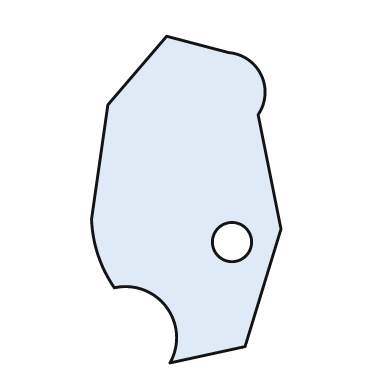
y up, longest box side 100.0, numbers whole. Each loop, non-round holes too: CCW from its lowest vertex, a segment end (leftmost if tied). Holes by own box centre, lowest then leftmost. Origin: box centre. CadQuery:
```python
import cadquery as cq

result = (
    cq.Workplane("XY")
    .moveTo(-5.0, -50.0)
    .lineTo(18.0, -45.0)
    .lineTo(29.0, -9.0)
    .lineTo(22.0, 26.0)
    .threePointArc((23.0, 38.0), (13.0, 45.0))
    .lineTo(-6.0, 50.0)
    .lineTo(-24.0, 29.0)
    .lineTo(-29.0, -6.0)
    .threePointArc((-27.0, -17.0), (-22.0, -27.0))
    .threePointArc((-6.0, -33.0), (-5.0, -50.0))
    .close()
    .moveTo(14.0, -13.0)
    .circle(6.0)
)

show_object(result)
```